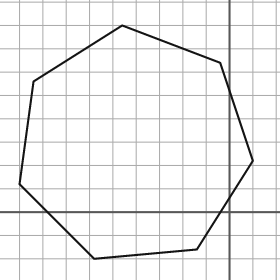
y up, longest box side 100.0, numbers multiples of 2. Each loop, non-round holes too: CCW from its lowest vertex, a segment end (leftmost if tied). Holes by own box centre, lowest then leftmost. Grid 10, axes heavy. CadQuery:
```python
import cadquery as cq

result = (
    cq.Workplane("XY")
    .moveTo(-58.0, -20.0)
    .lineTo(-14.0, -16.0)
    .lineTo(10.0, 22.0)
    .lineTo(-4.0, 64.0)
    .lineTo(-46.0, 80.0)
    .lineTo(-84.0, 56.0)
    .lineTo(-90.0, 12.0)
    .close()
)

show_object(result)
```